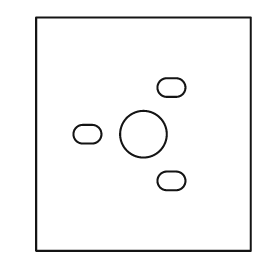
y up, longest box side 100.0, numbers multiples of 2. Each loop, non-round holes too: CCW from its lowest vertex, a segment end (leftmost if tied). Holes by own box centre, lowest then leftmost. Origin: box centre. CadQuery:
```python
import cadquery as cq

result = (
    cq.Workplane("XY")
    .moveTo(-46.0, -50.0)
    .lineTo(46.0, -50.0)
    .lineTo(46.0, 50.0)
    .lineTo(-46.0, 50.0)
    .close()
    .moveTo(10.0, -24.0)
    .lineTo(14.0, -24.0)
    .threePointArc((18.0, -20.0), (14.0, -16.0))
    .lineTo(10.0, -16.0)
    .threePointArc((6.0, -20.0), (10.0, -24.0))
    .close()
    .moveTo(-26.0, -4.0)
    .lineTo(-22.0, -4.0)
    .threePointArc((-18.0, 0.0), (-22.0, 4.0))
    .lineTo(-26.0, 4.0)
    .threePointArc((-30.0, 0.0), (-26.0, -4.0))
    .close()
    .moveTo(0.0, 0.0)
    .circle(10.0)
    .moveTo(10.0, 16.0)
    .lineTo(14.0, 16.0)
    .threePointArc((18.0, 20.0), (14.0, 24.0))
    .lineTo(10.0, 24.0)
    .threePointArc((6.0, 20.0), (10.0, 16.0))
    .close()
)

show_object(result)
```